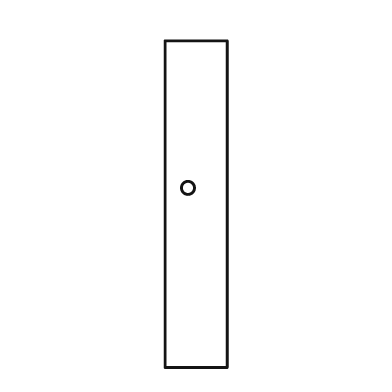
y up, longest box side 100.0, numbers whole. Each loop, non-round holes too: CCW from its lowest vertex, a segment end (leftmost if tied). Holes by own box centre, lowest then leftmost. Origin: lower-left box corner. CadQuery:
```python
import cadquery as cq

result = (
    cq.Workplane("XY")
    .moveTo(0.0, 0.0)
    .lineTo(19.0, 0.0)
    .lineTo(19.0, 100.0)
    .lineTo(0.0, 100.0)
    .close()
    .moveTo(7.0, 55.0)
    .circle(2.0)
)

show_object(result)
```